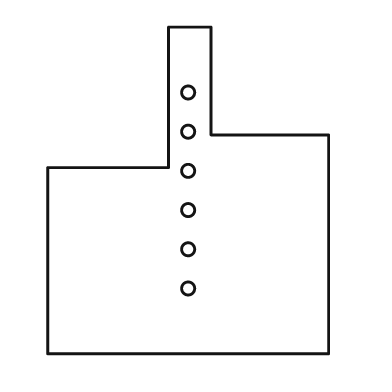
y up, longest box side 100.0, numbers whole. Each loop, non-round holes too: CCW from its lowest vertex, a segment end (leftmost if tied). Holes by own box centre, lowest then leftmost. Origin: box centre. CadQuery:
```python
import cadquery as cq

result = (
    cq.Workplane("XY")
    .moveTo(-43.0, -50.0)
    .lineTo(43.0, -50.0)
    .lineTo(43.0, 17.0)
    .lineTo(7.0, 17.0)
    .lineTo(7.0, 50.0)
    .lineTo(-6.0, 50.0)
    .lineTo(-6.0, 7.0)
    .lineTo(-43.0, 7.0)
    .close()
    .moveTo(0.0, -30.0)
    .circle(2.0)
    .moveTo(0.0, -18.0)
    .circle(2.0)
    .moveTo(0.0, -6.0)
    .circle(2.0)
    .moveTo(0.0, 6.0)
    .circle(2.0)
    .moveTo(0.0, 18.0)
    .circle(2.0)
    .moveTo(0.0, 30.0)
    .circle(2.0)
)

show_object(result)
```